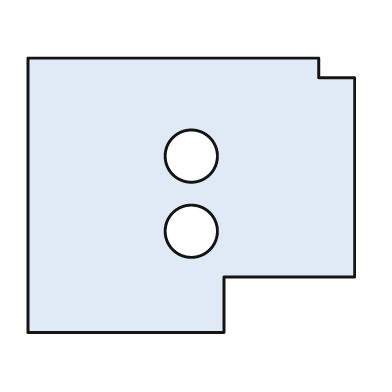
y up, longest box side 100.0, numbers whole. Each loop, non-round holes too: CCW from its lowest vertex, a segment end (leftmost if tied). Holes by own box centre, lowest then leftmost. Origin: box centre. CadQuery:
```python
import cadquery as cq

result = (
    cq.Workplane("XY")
    .moveTo(-50.0, -42.0)
    .lineTo(10.0, -42.0)
    .lineTo(10.0, -25.0)
    .lineTo(50.0, -25.0)
    .lineTo(50.0, 36.0)
    .lineTo(39.0, 36.0)
    .lineTo(39.0, 42.0)
    .lineTo(-50.0, 42.0)
    .close()
    .moveTo(0.0, -11.0)
    .circle(8.0)
    .moveTo(0.0, 12.0)
    .circle(8.0)
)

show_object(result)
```